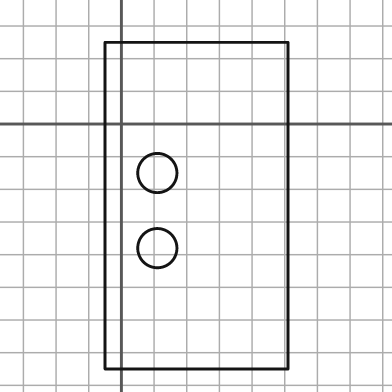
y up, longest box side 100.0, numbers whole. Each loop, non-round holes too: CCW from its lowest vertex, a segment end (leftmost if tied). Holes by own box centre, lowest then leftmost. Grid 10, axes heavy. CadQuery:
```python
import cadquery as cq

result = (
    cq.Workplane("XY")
    .moveTo(-5.0, -75.0)
    .lineTo(51.0, -75.0)
    .lineTo(51.0, 25.0)
    .lineTo(-5.0, 25.0)
    .close()
    .moveTo(11.0, -38.0)
    .circle(6.0)
    .moveTo(11.0, -15.0)
    .circle(6.0)
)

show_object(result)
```